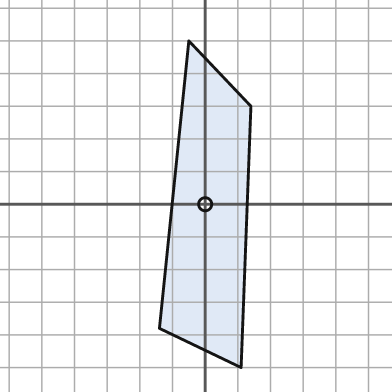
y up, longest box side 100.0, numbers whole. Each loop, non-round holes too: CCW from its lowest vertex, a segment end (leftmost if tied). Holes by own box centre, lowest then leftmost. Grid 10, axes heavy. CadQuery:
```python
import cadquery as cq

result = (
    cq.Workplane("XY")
    .moveTo(11.0, -50.0)
    .lineTo(14.0, 30.0)
    .lineTo(-5.0, 50.0)
    .lineTo(-14.0, -38.0)
    .close()
    .moveTo(0.0, 0.0)
    .circle(2.0)
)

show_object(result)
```